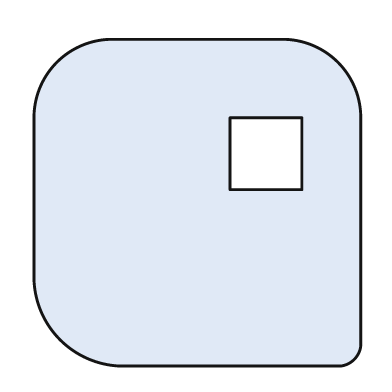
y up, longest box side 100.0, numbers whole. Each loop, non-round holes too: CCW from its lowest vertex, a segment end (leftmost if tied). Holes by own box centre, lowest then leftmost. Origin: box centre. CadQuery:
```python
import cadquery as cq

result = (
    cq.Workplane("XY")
    .moveTo(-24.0, -50.0)
    .lineTo(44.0, -50.0)
    .threePointArc((48.0, -48.0), (50.0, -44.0))
    .lineTo(50.0, 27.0)
    .threePointArc((43.0, 43.0), (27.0, 50.0))
    .lineTo(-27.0, 50.0)
    .threePointArc((-43.0, 43.0), (-50.0, 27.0))
    .lineTo(-50.0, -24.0)
    .threePointArc((-42.0, -42.0), (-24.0, -50.0))
    .close()
    .moveTo(10.0, 4.0)
    .lineTo(32.0, 4.0)
    .lineTo(32.0, 26.0)
    .lineTo(10.0, 26.0)
    .close()
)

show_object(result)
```